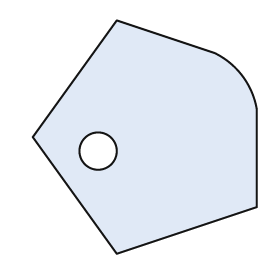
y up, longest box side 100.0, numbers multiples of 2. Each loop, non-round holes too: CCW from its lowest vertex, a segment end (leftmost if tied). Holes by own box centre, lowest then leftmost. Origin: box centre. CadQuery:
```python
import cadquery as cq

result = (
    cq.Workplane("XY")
    .moveTo(-12.0, -50.0)
    .lineTo(48.0, -30.0)
    .lineTo(48.0, 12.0)
    .threePointArc((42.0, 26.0), (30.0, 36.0))
    .lineTo(-12.0, 50.0)
    .lineTo(-48.0, 0.0)
    .close()
    .moveTo(-20.0, -6.0)
    .circle(8.0)
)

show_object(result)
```